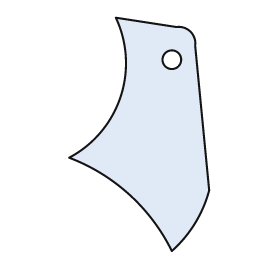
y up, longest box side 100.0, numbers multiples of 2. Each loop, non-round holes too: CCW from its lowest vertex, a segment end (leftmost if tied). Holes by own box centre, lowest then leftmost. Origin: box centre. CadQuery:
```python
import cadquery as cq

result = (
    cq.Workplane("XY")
    .moveTo(14.0, -50.0)
    .threePointArc((24.0, -38.0), (30.0, -24.0))
    .lineTo(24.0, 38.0)
    .threePointArc((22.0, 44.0), (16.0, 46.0))
    .lineTo(-10.0, 50.0)
    .threePointArc((-8.0, 16.0), (-30.0, -10.0))
    .threePointArc((-4.0, -26.0), (14.0, -50.0))
    .close()
    .moveTo(14.0, 32.0)
    .circle(4.0)
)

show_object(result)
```